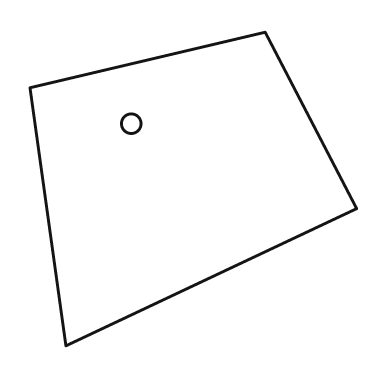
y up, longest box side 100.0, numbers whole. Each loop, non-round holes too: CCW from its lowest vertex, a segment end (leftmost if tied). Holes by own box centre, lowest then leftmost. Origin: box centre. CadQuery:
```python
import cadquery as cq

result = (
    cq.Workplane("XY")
    .moveTo(-39.0, -48.0)
    .lineTo(50.0, -6.0)
    .lineTo(22.0, 48.0)
    .lineTo(-50.0, 31.0)
    .close()
    .moveTo(-19.0, 20.0)
    .circle(3.0)
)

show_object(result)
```